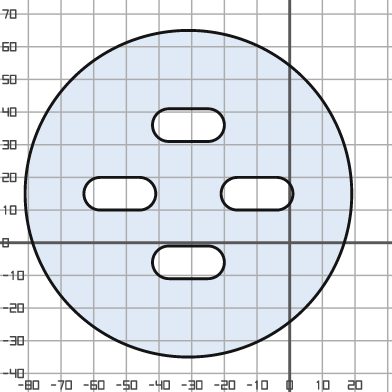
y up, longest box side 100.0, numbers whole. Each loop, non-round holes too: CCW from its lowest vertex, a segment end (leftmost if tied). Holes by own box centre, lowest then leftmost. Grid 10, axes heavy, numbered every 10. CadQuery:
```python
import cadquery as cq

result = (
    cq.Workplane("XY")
    .moveTo(-31.0, 15.0)
    .circle(50.0)
    .moveTo(-37.0, -11.0)
    .lineTo(-25.0, -11.0)
    .threePointArc((-20.0, -6.0), (-25.0, -1.0))
    .lineTo(-37.0, -1.0)
    .threePointArc((-42.0, -6.0), (-37.0, -11.0))
    .close()
    .moveTo(-58.0, 10.0)
    .lineTo(-46.0, 10.0)
    .threePointArc((-41.0, 15.0), (-46.0, 20.0))
    .lineTo(-58.0, 20.0)
    .threePointArc((-63.0, 15.0), (-58.0, 10.0))
    .close()
    .moveTo(-16.0, 10.0)
    .lineTo(-4.0, 10.0)
    .threePointArc((1.0, 15.0), (-4.0, 20.0))
    .lineTo(-16.0, 20.0)
    .threePointArc((-21.0, 15.0), (-16.0, 10.0))
    .close()
    .moveTo(-37.0, 31.0)
    .lineTo(-25.0, 31.0)
    .threePointArc((-20.0, 36.0), (-25.0, 41.0))
    .lineTo(-37.0, 41.0)
    .threePointArc((-42.0, 36.0), (-37.0, 31.0))
    .close()
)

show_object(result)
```